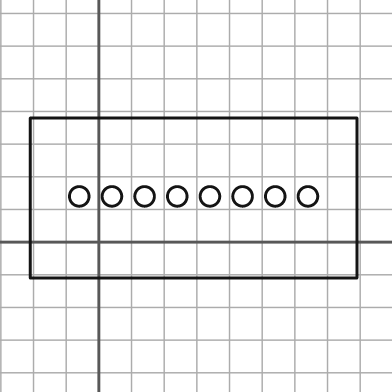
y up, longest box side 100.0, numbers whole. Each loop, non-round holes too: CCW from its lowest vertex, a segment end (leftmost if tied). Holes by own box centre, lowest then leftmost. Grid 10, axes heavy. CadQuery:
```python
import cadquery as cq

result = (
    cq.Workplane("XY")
    .moveTo(-21.0, -11.0)
    .lineTo(79.0, -11.0)
    .lineTo(79.0, 38.0)
    .lineTo(-21.0, 38.0)
    .close()
    .moveTo(-6.0, 14.0)
    .circle(3.0)
    .moveTo(4.0, 14.0)
    .circle(3.0)
    .moveTo(14.0, 14.0)
    .circle(3.0)
    .moveTo(24.0, 14.0)
    .circle(3.0)
    .moveTo(34.0, 14.0)
    .circle(3.0)
    .moveTo(44.0, 14.0)
    .circle(3.0)
    .moveTo(54.0, 14.0)
    .circle(3.0)
    .moveTo(64.0, 14.0)
    .circle(3.0)
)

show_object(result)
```